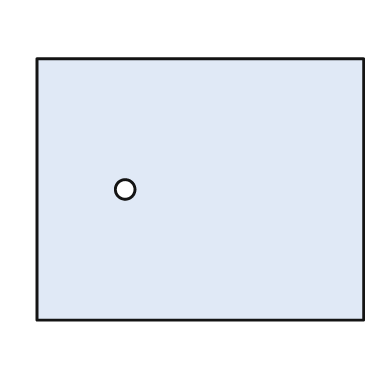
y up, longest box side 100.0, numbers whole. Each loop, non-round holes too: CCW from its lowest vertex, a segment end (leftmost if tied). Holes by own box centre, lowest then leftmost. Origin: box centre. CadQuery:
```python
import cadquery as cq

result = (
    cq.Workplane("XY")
    .moveTo(-50.0, -40.0)
    .lineTo(50.0, -40.0)
    .lineTo(50.0, 40.0)
    .lineTo(-50.0, 40.0)
    .close()
    .moveTo(-23.0, 0.0)
    .circle(3.0)
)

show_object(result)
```